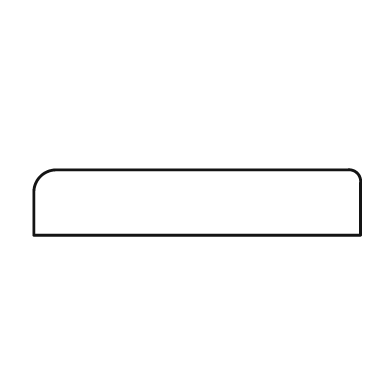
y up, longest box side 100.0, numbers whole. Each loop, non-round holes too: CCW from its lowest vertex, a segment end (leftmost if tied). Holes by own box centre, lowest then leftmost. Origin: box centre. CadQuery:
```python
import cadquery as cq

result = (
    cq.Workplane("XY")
    .moveTo(-50.0, -10.0)
    .lineTo(50.0, -10.0)
    .lineTo(50.0, 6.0)
    .threePointArc((49.0, 9.0), (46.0, 10.0))
    .lineTo(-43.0, 10.0)
    .threePointArc((-48.0, 8.0), (-50.0, 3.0))
    .close()
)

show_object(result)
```